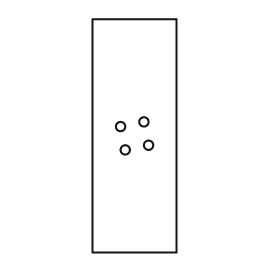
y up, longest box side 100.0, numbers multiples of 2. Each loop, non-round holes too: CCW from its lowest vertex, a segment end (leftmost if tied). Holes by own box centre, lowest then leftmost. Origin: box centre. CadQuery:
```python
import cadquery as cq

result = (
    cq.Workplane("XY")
    .moveTo(-18.0, -50.0)
    .lineTo(18.0, -50.0)
    .lineTo(18.0, 50.0)
    .lineTo(-18.0, 50.0)
    .close()
    .moveTo(-4.0, -6.0)
    .circle(2.0)
    .moveTo(6.0, -4.0)
    .circle(2.0)
    .moveTo(-6.0, 4.0)
    .circle(2.0)
    .moveTo(4.0, 6.0)
    .circle(2.0)
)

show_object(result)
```